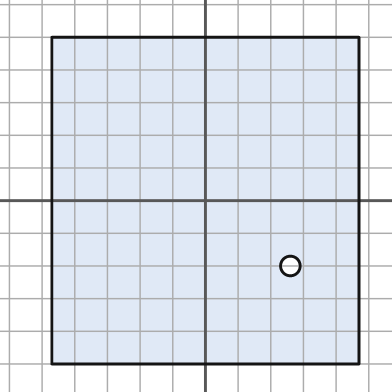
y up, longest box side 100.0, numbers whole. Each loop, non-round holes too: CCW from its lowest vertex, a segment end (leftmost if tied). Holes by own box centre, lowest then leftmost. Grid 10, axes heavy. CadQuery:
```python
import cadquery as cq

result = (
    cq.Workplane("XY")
    .moveTo(-47.0, -50.0)
    .lineTo(47.0, -50.0)
    .lineTo(47.0, 50.0)
    .lineTo(-47.0, 50.0)
    .close()
    .moveTo(26.0, -20.0)
    .circle(3.0)
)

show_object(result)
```